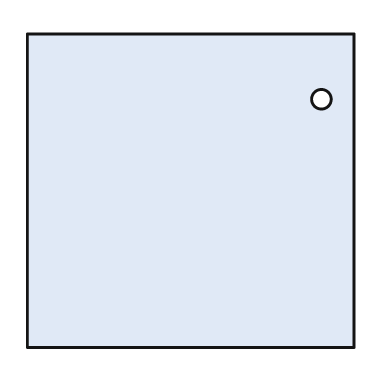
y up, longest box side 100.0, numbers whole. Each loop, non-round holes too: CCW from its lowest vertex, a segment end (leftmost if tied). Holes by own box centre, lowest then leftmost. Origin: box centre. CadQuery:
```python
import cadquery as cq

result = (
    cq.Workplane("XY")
    .moveTo(-50.0, -48.0)
    .lineTo(50.0, -48.0)
    .lineTo(50.0, 48.0)
    .lineTo(-50.0, 48.0)
    .close()
    .moveTo(40.0, 28.0)
    .circle(3.0)
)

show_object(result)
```